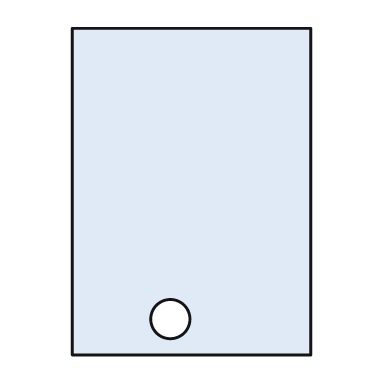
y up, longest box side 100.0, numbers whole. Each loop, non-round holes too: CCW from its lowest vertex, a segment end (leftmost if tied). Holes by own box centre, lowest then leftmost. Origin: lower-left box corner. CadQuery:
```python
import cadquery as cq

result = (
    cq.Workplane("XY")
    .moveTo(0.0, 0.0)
    .lineTo(73.0, 0.0)
    .lineTo(73.0, 100.0)
    .lineTo(0.0, 100.0)
    .close()
    .moveTo(30.0, 11.0)
    .circle(6.0)
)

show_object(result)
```